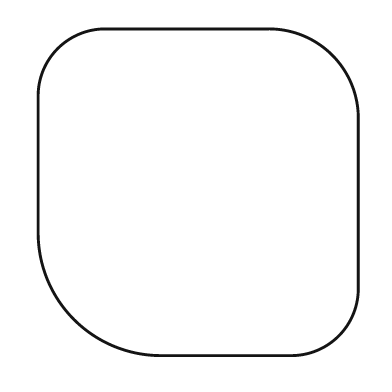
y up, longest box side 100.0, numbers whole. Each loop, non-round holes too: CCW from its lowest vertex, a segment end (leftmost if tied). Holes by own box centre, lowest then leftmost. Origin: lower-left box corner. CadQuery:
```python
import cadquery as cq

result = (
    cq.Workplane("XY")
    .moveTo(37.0, 0.0)
    .lineTo(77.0, 0.0)
    .threePointArc((92.0, 6.0), (98.0, 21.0))
    .lineTo(98.0, 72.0)
    .threePointArc((90.0, 92.0), (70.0, 100.0))
    .lineTo(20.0, 100.0)
    .threePointArc((6.0, 94.0), (0.0, 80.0))
    .lineTo(0.0, 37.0)
    .threePointArc((11.0, 11.0), (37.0, 0.0))
    .close()
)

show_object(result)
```